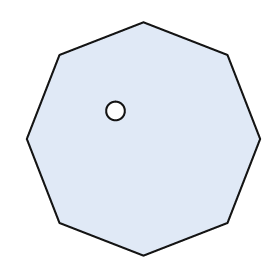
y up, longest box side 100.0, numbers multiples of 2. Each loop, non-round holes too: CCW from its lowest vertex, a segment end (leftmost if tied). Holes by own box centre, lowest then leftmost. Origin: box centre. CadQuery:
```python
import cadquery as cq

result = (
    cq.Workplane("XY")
    .moveTo(0.0, -50.0)
    .lineTo(36.0, -36.0)
    .lineTo(50.0, 0.0)
    .lineTo(36.0, 36.0)
    .lineTo(0.0, 50.0)
    .lineTo(-36.0, 36.0)
    .lineTo(-50.0, 0.0)
    .lineTo(-36.0, -36.0)
    .close()
    .moveTo(-12.0, 12.0)
    .circle(4.0)
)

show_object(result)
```